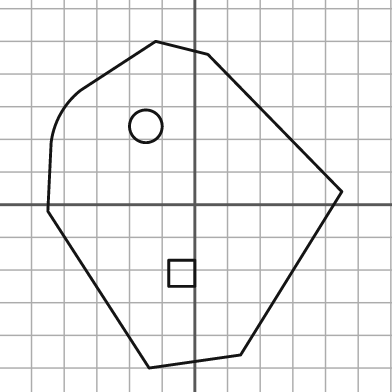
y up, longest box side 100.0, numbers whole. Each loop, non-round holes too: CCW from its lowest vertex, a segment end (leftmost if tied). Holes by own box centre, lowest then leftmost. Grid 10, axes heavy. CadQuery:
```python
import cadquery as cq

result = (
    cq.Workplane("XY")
    .moveTo(-14.0, -50.0)
    .lineTo(14.0, -46.0)
    .lineTo(45.0, 4.0)
    .lineTo(4.0, 46.0)
    .lineTo(-12.0, 50.0)
    .lineTo(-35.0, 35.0)
    .threePointArc((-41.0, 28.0), (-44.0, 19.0))
    .lineTo(-45.0, -2.0)
    .close()
    .moveTo(-8.0, -25.0)
    .lineTo(0.0, -25.0)
    .lineTo(0.0, -17.0)
    .lineTo(-8.0, -17.0)
    .close()
    .moveTo(-15.0, 24.0)
    .circle(5.0)
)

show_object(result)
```